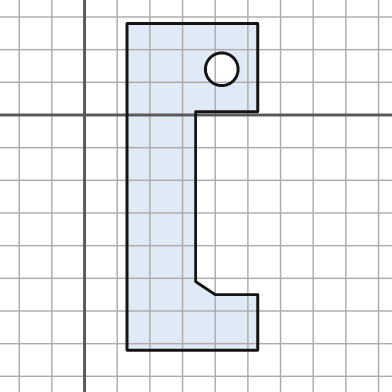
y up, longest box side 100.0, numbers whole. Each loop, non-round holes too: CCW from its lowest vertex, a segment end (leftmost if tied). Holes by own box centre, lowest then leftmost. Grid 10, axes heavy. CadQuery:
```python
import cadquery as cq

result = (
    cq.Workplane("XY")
    .moveTo(13.0, -72.0)
    .lineTo(53.0, -72.0)
    .lineTo(53.0, -55.0)
    .lineTo(40.0, -55.0)
    .lineTo(34.0, -51.0)
    .lineTo(34.0, 1.0)
    .lineTo(53.0, 1.0)
    .lineTo(53.0, 28.0)
    .lineTo(13.0, 28.0)
    .close()
    .moveTo(42.0, 14.0)
    .circle(5.0)
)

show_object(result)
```